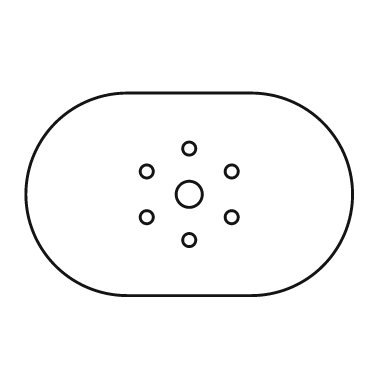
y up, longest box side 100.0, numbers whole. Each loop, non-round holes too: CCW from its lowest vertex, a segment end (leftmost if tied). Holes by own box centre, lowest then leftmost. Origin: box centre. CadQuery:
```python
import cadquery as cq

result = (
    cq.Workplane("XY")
    .moveTo(-19.0, -31.0)
    .lineTo(19.0, -31.0)
    .threePointArc((50.0, 0.0), (19.0, 31.0))
    .lineTo(-19.0, 31.0)
    .threePointArc((-50.0, 0.0), (-19.0, -31.0))
    .close()
    .moveTo(0.0, -14.0)
    .circle(2.0)
    .moveTo(-13.0, -7.0)
    .circle(2.0)
    .moveTo(13.0, -7.0)
    .circle(2.0)
    .moveTo(0.0, 0.0)
    .circle(4.0)
    .moveTo(-13.0, 7.0)
    .circle(2.0)
    .moveTo(13.0, 7.0)
    .circle(2.0)
    .moveTo(0.0, 14.0)
    .circle(2.0)
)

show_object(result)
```